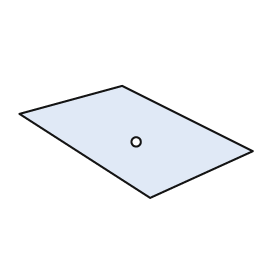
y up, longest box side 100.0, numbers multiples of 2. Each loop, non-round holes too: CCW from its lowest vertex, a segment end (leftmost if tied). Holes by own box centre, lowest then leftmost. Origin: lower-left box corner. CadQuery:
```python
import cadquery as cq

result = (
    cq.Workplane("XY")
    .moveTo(56.0, 0.0)
    .lineTo(100.0, 20.0)
    .lineTo(44.0, 48.0)
    .lineTo(0.0, 36.0)
    .close()
    .moveTo(50.0, 24.0)
    .circle(2.0)
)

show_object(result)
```